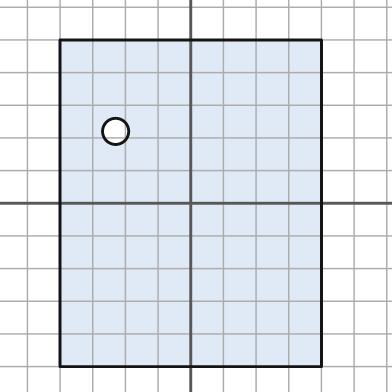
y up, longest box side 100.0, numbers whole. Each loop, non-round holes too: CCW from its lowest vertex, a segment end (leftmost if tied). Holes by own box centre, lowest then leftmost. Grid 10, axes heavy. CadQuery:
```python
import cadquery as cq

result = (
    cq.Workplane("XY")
    .moveTo(-40.0, -50.0)
    .lineTo(40.0, -50.0)
    .lineTo(40.0, 50.0)
    .lineTo(-40.0, 50.0)
    .close()
    .moveTo(-23.0, 22.0)
    .circle(4.0)
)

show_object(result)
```